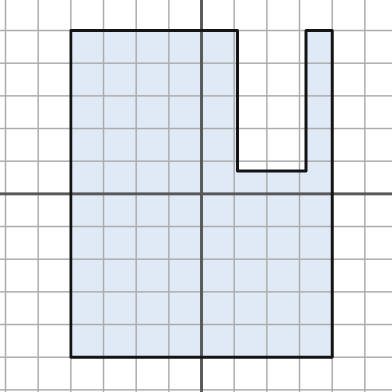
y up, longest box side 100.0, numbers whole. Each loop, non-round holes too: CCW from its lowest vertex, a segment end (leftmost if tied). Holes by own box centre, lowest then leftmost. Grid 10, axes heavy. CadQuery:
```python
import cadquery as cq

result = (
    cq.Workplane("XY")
    .moveTo(-40.0, -50.0)
    .lineTo(40.0, -50.0)
    .lineTo(40.0, 50.0)
    .lineTo(32.0, 50.0)
    .lineTo(32.0, 7.0)
    .lineTo(11.0, 7.0)
    .lineTo(11.0, 50.0)
    .lineTo(-40.0, 50.0)
    .close()
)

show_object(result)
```